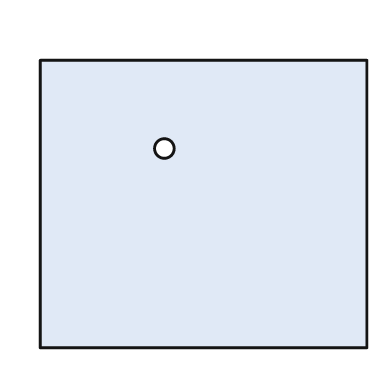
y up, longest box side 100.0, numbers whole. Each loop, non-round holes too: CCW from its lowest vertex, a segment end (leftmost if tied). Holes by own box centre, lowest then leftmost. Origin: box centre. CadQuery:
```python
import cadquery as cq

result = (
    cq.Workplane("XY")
    .moveTo(-50.0, -44.0)
    .lineTo(50.0, -44.0)
    .lineTo(50.0, 44.0)
    .lineTo(-50.0, 44.0)
    .close()
    .moveTo(-12.0, 17.0)
    .circle(3.0)
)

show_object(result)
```